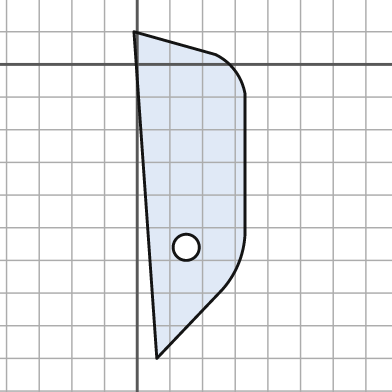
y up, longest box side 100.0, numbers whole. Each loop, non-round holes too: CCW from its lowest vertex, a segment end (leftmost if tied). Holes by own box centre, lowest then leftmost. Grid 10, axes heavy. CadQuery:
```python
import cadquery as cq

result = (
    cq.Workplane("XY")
    .moveTo(6.0, -90.0)
    .lineTo(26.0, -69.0)
    .threePointArc((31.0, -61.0), (33.0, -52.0))
    .lineTo(33.0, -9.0)
    .threePointArc((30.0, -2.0), (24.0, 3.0))
    .lineTo(-1.0, 10.0)
    .close()
    .moveTo(15.0, -56.0)
    .circle(4.0)
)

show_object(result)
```